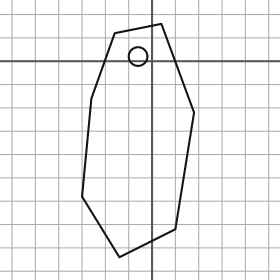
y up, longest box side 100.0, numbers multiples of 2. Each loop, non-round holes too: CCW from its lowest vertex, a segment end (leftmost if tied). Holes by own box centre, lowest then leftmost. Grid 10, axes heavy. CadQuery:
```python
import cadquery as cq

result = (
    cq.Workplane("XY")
    .moveTo(-14.0, -84.0)
    .lineTo(10.0, -72.0)
    .lineTo(18.0, -22.0)
    .lineTo(4.0, 16.0)
    .lineTo(-16.0, 12.0)
    .lineTo(-26.0, -16.0)
    .lineTo(-30.0, -58.0)
    .close()
    .moveTo(-6.0, 2.0)
    .circle(4.0)
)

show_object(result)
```